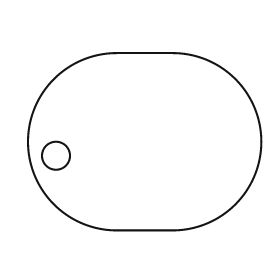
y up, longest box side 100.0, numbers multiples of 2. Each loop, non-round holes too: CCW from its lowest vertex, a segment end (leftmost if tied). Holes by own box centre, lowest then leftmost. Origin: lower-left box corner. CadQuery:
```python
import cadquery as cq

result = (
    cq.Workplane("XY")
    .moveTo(38.0, 0.0)
    .lineTo(62.0, 0.0)
    .threePointArc((100.0, 38.0), (62.0, 76.0))
    .lineTo(38.0, 76.0)
    .threePointArc((0.0, 38.0), (38.0, 0.0))
    .close()
    .moveTo(12.0, 32.0)
    .circle(6.0)
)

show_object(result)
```